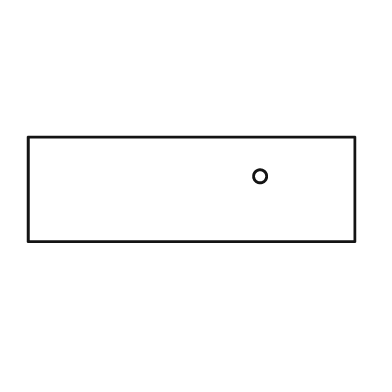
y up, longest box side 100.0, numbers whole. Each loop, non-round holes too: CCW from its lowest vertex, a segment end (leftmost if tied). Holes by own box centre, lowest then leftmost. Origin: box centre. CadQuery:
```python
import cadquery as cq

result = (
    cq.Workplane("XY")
    .moveTo(-50.0, -16.0)
    .lineTo(50.0, -16.0)
    .lineTo(50.0, 16.0)
    .lineTo(-50.0, 16.0)
    .close()
    .moveTo(21.0, 4.0)
    .circle(2.0)
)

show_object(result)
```